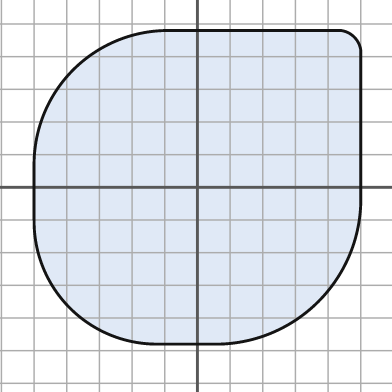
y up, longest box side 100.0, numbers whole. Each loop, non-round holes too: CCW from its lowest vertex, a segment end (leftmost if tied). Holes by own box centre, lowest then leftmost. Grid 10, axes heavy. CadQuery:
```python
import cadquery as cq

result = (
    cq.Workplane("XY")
    .moveTo(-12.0, -48.0)
    .lineTo(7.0, -48.0)
    .threePointArc((37.0, -35.0), (50.0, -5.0))
    .lineTo(50.0, 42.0)
    .threePointArc((48.0, 46.0), (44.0, 48.0))
    .lineTo(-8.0, 48.0)
    .threePointArc((-38.0, 36.0), (-50.0, 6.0))
    .lineTo(-50.0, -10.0)
    .threePointArc((-39.0, -37.0), (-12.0, -48.0))
    .close()
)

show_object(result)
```